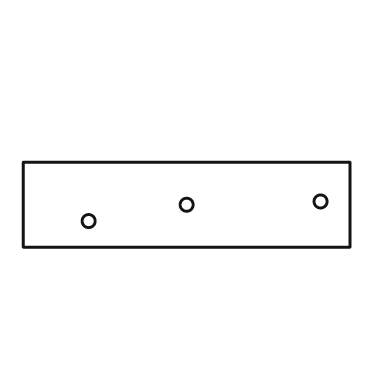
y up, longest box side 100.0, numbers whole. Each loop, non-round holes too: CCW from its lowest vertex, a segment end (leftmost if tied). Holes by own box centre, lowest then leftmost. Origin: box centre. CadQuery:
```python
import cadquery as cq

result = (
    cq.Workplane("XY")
    .moveTo(-50.0, -13.0)
    .lineTo(50.0, -13.0)
    .lineTo(50.0, 13.0)
    .lineTo(-50.0, 13.0)
    .close()
    .moveTo(-30.0, -5.0)
    .circle(2.0)
    .moveTo(0.0, 0.0)
    .circle(2.0)
    .moveTo(41.0, 1.0)
    .circle(2.0)
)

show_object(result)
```